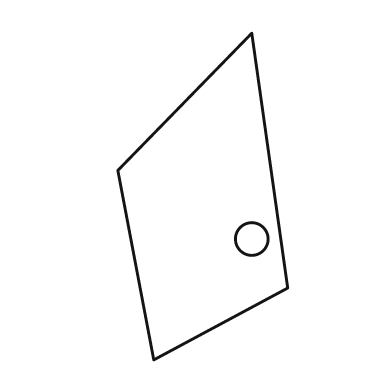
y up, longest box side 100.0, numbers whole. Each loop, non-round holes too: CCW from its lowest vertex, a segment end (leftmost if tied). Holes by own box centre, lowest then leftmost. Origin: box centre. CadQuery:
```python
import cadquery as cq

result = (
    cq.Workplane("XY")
    .moveTo(-15.0, -50.0)
    .lineTo(26.0, -28.0)
    .lineTo(15.0, 50.0)
    .lineTo(-26.0, 8.0)
    .close()
    .moveTo(15.0, -13.0)
    .circle(5.0)
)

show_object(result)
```